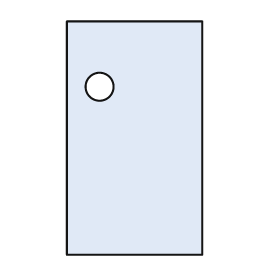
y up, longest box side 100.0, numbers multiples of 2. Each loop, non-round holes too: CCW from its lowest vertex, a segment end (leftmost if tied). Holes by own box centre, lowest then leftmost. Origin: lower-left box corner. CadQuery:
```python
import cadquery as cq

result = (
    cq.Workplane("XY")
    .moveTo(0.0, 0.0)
    .lineTo(58.0, 0.0)
    .lineTo(58.0, 100.0)
    .lineTo(0.0, 100.0)
    .close()
    .moveTo(14.0, 72.0)
    .circle(6.0)
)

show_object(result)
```